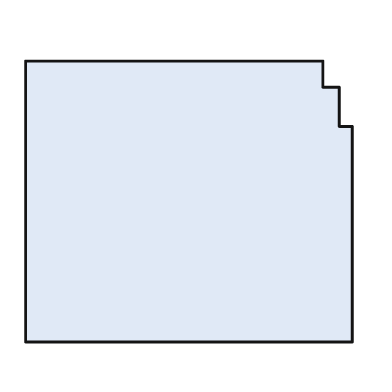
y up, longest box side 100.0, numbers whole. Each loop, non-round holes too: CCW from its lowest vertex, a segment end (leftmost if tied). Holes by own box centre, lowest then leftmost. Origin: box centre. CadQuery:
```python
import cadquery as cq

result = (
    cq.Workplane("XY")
    .moveTo(-50.0, -43.0)
    .lineTo(50.0, -43.0)
    .lineTo(50.0, 23.0)
    .lineTo(46.0, 23.0)
    .lineTo(46.0, 35.0)
    .lineTo(41.0, 35.0)
    .lineTo(41.0, 43.0)
    .lineTo(-50.0, 43.0)
    .close()
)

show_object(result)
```